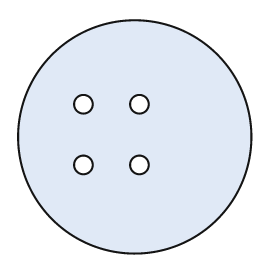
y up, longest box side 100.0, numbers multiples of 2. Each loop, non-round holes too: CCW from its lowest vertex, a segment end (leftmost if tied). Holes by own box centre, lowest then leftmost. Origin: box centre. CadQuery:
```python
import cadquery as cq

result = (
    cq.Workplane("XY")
    .moveTo(0.0, 0.0)
    .circle(50.0)
    .moveTo(-22.0, -12.0)
    .circle(4.0)
    .moveTo(2.0, -12.0)
    .circle(4.0)
    .moveTo(-22.0, 14.0)
    .circle(4.0)
    .moveTo(2.0, 14.0)
    .circle(4.0)
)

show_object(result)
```